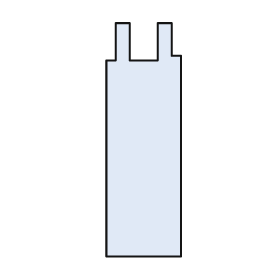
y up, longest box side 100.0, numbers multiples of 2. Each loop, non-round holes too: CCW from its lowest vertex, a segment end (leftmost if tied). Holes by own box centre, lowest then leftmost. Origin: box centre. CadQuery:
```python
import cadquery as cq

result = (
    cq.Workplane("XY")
    .moveTo(-16.0, -50.0)
    .lineTo(16.0, -50.0)
    .lineTo(16.0, 36.0)
    .lineTo(12.0, 36.0)
    .lineTo(12.0, 50.0)
    .lineTo(6.0, 50.0)
    .lineTo(6.0, 34.0)
    .lineTo(-6.0, 34.0)
    .lineTo(-6.0, 50.0)
    .lineTo(-12.0, 50.0)
    .lineTo(-12.0, 34.0)
    .lineTo(-16.0, 34.0)
    .close()
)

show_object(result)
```